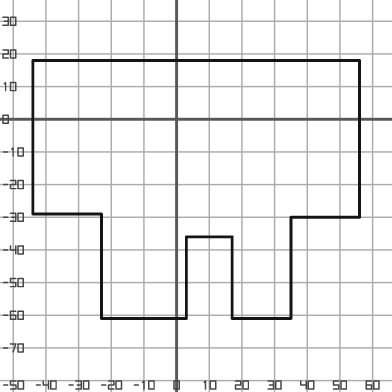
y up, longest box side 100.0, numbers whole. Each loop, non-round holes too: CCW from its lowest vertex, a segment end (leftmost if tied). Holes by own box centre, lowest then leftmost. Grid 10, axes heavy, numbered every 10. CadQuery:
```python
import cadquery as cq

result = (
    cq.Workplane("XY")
    .moveTo(-23.0, -61.0)
    .lineTo(3.0, -61.0)
    .lineTo(3.0, -36.0)
    .lineTo(17.0, -36.0)
    .lineTo(17.0, -61.0)
    .lineTo(35.0, -61.0)
    .lineTo(35.0, -30.0)
    .lineTo(56.0, -30.0)
    .lineTo(56.0, 18.0)
    .lineTo(-44.0, 18.0)
    .lineTo(-44.0, -29.0)
    .lineTo(-23.0, -29.0)
    .close()
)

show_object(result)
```